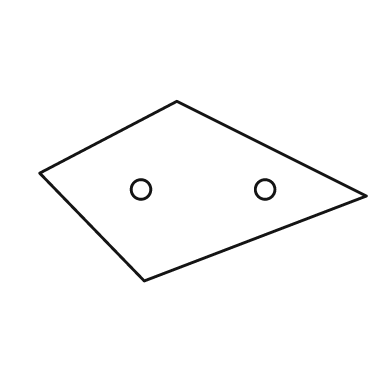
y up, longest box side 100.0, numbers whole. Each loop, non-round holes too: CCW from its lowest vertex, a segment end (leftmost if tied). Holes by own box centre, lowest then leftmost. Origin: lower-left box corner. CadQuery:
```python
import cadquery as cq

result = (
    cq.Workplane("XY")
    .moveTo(32.0, 0.0)
    .lineTo(100.0, 26.0)
    .lineTo(42.0, 55.0)
    .lineTo(0.0, 33.0)
    .close()
    .moveTo(31.0, 28.0)
    .circle(3.0)
    .moveTo(69.0, 28.0)
    .circle(3.0)
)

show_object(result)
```